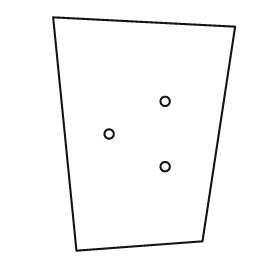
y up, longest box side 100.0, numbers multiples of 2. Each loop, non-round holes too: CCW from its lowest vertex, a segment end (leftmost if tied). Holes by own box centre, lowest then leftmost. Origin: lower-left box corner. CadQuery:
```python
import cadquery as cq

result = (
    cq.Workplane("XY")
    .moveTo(10.0, 0.0)
    .lineTo(64.0, 4.0)
    .lineTo(78.0, 96.0)
    .lineTo(0.0, 100.0)
    .close()
    .moveTo(48.0, 36.0)
    .circle(2.0)
    .moveTo(24.0, 50.0)
    .circle(2.0)
    .moveTo(48.0, 64.0)
    .circle(2.0)
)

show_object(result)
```